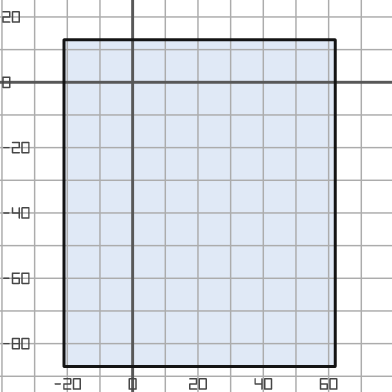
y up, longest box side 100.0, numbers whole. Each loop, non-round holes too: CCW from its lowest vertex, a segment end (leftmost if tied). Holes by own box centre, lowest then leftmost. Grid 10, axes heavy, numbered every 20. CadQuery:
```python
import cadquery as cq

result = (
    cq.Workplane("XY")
    .moveTo(-21.0, -87.0)
    .lineTo(62.0, -87.0)
    .lineTo(62.0, 13.0)
    .lineTo(-21.0, 13.0)
    .close()
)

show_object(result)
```